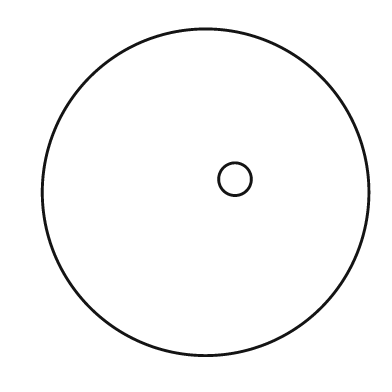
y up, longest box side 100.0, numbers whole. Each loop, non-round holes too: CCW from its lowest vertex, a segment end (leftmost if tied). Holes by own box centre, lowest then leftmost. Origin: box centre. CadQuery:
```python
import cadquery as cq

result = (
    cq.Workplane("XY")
    .moveTo(0.0, 0.0)
    .circle(50.0)
    .moveTo(9.0, 4.0)
    .circle(5.0)
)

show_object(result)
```